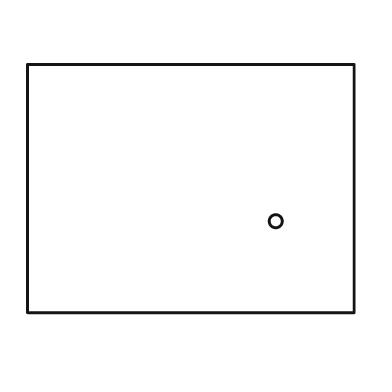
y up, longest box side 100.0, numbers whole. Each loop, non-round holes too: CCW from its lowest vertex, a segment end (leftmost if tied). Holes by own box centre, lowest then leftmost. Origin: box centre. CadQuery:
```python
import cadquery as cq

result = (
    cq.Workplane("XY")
    .moveTo(-50.0, -38.0)
    .lineTo(50.0, -38.0)
    .lineTo(50.0, 38.0)
    .lineTo(-50.0, 38.0)
    .close()
    .moveTo(26.0, -10.0)
    .circle(2.0)
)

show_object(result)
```